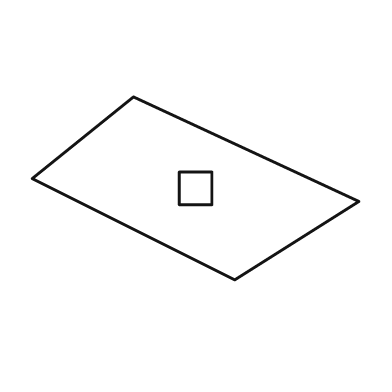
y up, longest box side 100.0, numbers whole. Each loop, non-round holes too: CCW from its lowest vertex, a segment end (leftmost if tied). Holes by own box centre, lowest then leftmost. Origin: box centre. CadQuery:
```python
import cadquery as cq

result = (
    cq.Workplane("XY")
    .moveTo(12.0, -28.0)
    .lineTo(50.0, -4.0)
    .lineTo(-19.0, 28.0)
    .lineTo(-50.0, 3.0)
    .close()
    .moveTo(-5.0, -5.0)
    .lineTo(5.0, -5.0)
    .lineTo(5.0, 5.0)
    .lineTo(-5.0, 5.0)
    .close()
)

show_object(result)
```